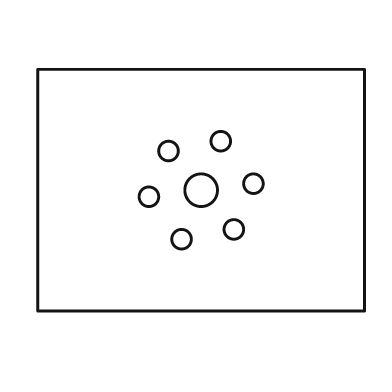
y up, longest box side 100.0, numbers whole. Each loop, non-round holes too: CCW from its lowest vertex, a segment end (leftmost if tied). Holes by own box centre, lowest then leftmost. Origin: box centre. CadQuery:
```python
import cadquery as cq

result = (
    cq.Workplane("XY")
    .moveTo(-50.0, -37.0)
    .lineTo(50.0, -37.0)
    .lineTo(50.0, 37.0)
    .lineTo(-50.0, 37.0)
    .close()
    .moveTo(-6.0, -15.0)
    .circle(3.0)
    .moveTo(10.0, -12.0)
    .circle(3.0)
    .moveTo(-16.0, -2.0)
    .circle(3.0)
    .moveTo(0.0, 0.0)
    .circle(5.0)
    .moveTo(16.0, 2.0)
    .circle(3.0)
    .moveTo(-10.0, 12.0)
    .circle(3.0)
    .moveTo(6.0, 15.0)
    .circle(3.0)
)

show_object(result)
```